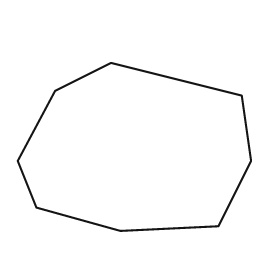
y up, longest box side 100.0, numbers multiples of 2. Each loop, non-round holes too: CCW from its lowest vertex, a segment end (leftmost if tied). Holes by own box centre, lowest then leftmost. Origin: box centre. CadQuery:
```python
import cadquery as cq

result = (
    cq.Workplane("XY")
    .moveTo(-6.0, -36.0)
    .lineTo(36.0, -34.0)
    .lineTo(50.0, -6.0)
    .lineTo(46.0, 22.0)
    .lineTo(-10.0, 36.0)
    .lineTo(-34.0, 24.0)
    .lineTo(-50.0, -6.0)
    .lineTo(-42.0, -26.0)
    .close()
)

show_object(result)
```